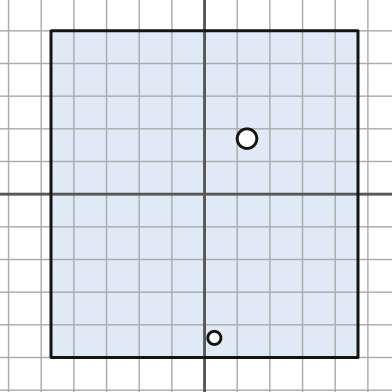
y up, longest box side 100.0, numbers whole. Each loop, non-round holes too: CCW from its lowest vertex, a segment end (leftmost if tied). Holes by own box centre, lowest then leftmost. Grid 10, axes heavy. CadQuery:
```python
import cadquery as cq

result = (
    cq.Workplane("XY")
    .moveTo(-47.0, -50.0)
    .lineTo(47.0, -50.0)
    .lineTo(47.0, 50.0)
    .lineTo(-47.0, 50.0)
    .close()
    .moveTo(3.0, -44.0)
    .circle(2.0)
    .moveTo(13.0, 17.0)
    .circle(3.0)
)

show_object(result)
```